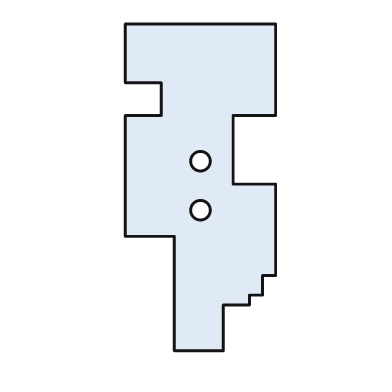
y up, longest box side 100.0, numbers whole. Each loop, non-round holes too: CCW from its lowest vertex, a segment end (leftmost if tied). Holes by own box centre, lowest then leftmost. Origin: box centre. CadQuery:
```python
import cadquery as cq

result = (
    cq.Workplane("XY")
    .moveTo(-8.0, -50.0)
    .lineTo(7.0, -50.0)
    .lineTo(7.0, -36.0)
    .lineTo(15.0, -36.0)
    .lineTo(15.0, -33.0)
    .lineTo(19.0, -33.0)
    .lineTo(19.0, -27.0)
    .lineTo(23.0, -27.0)
    .lineTo(23.0, 1.0)
    .lineTo(10.0, 1.0)
    .lineTo(10.0, 22.0)
    .lineTo(23.0, 22.0)
    .lineTo(23.0, 50.0)
    .lineTo(-23.0, 50.0)
    .lineTo(-23.0, 32.0)
    .lineTo(-12.0, 32.0)
    .lineTo(-12.0, 22.0)
    .lineTo(-23.0, 22.0)
    .lineTo(-23.0, -15.0)
    .lineTo(-8.0, -15.0)
    .close()
    .moveTo(0.0, -7.0)
    .circle(3.0)
    .moveTo(0.0, 8.0)
    .circle(3.0)
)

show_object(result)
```